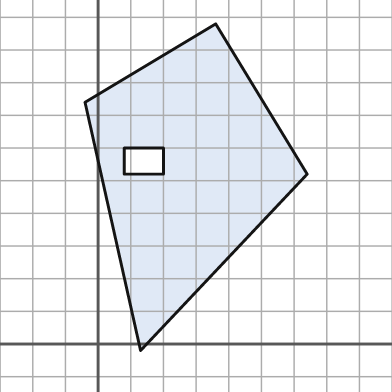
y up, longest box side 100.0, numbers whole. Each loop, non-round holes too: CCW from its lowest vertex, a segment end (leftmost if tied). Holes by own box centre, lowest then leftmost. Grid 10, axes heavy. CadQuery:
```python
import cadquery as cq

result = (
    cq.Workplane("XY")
    .moveTo(13.0, -2.0)
    .lineTo(64.0, 52.0)
    .lineTo(36.0, 98.0)
    .lineTo(-4.0, 74.0)
    .close()
    .moveTo(8.0, 52.0)
    .lineTo(20.0, 52.0)
    .lineTo(20.0, 60.0)
    .lineTo(8.0, 60.0)
    .close()
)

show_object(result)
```